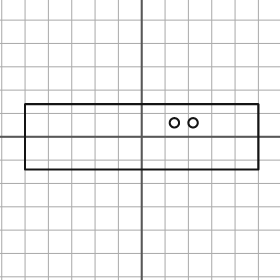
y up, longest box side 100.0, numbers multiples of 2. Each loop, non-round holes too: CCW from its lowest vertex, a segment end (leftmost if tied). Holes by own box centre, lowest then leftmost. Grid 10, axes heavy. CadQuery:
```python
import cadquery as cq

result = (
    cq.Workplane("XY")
    .moveTo(-50.0, -14.0)
    .lineTo(50.0, -14.0)
    .lineTo(50.0, 14.0)
    .lineTo(-50.0, 14.0)
    .close()
    .moveTo(14.0, 6.0)
    .circle(2.0)
    .moveTo(22.0, 6.0)
    .circle(2.0)
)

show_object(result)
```